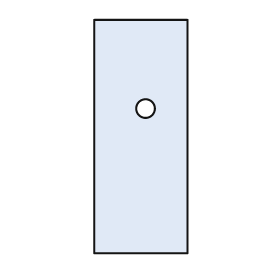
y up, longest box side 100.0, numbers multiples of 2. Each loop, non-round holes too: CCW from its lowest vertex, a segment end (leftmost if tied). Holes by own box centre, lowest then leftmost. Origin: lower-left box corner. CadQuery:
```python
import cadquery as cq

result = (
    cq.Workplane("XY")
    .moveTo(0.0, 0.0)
    .lineTo(40.0, 0.0)
    .lineTo(40.0, 100.0)
    .lineTo(0.0, 100.0)
    .close()
    .moveTo(22.0, 62.0)
    .circle(4.0)
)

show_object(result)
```